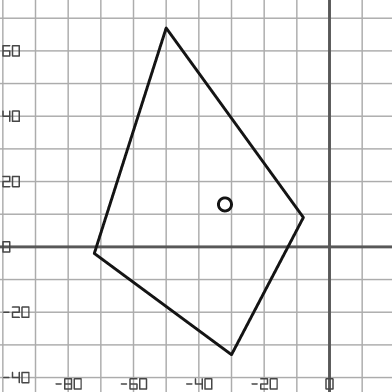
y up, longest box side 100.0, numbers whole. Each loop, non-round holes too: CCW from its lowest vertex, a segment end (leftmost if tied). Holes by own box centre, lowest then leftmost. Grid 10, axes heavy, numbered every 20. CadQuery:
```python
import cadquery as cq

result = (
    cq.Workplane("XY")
    .moveTo(-30.0, -33.0)
    .lineTo(-8.0, 9.0)
    .lineTo(-50.0, 67.0)
    .lineTo(-72.0, -2.0)
    .close()
    .moveTo(-32.0, 13.0)
    .circle(2.0)
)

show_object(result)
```